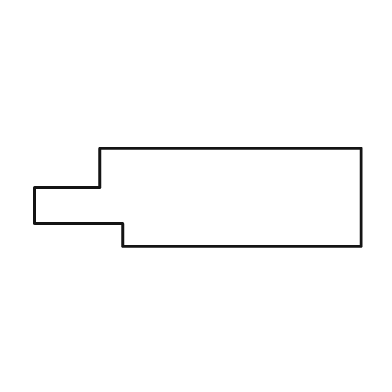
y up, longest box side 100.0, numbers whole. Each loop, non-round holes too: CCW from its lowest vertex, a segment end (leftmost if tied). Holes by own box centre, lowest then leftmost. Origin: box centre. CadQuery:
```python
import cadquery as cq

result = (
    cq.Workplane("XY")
    .moveTo(-23.0, -15.0)
    .lineTo(50.0, -15.0)
    .lineTo(50.0, 15.0)
    .lineTo(-30.0, 15.0)
    .lineTo(-30.0, 3.0)
    .lineTo(-50.0, 3.0)
    .lineTo(-50.0, -8.0)
    .lineTo(-23.0, -8.0)
    .close()
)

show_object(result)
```